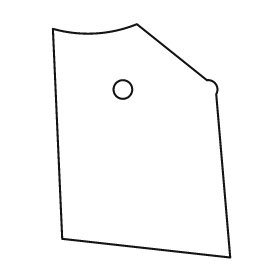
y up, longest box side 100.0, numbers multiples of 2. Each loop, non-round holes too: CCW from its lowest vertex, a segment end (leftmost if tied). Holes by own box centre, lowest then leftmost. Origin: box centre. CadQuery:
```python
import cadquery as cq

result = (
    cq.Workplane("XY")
    .moveTo(38.0, -50.0)
    .lineTo(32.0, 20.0)
    .threePointArc((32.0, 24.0), (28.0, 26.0))
    .lineTo(-2.0, 50.0)
    .threePointArc((-20.0, 46.0), (-38.0, 48.0))
    .lineTo(-34.0, -42.0)
    .close()
    .moveTo(-8.0, 22.0)
    .circle(4.0)
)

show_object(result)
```